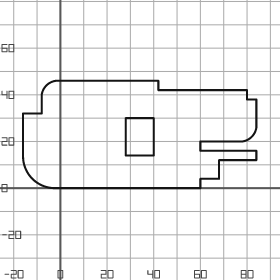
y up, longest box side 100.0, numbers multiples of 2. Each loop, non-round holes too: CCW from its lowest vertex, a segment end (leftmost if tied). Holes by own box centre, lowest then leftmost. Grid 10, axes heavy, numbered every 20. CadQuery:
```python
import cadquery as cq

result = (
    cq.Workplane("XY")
    .moveTo(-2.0, 0.0)
    .lineTo(60.0, 0.0)
    .lineTo(60.0, 4.0)
    .lineTo(68.0, 4.0)
    .lineTo(68.0, 12.0)
    .lineTo(84.0, 12.0)
    .lineTo(84.0, 16.0)
    .lineTo(60.0, 16.0)
    .lineTo(60.0, 20.0)
    .lineTo(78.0, 20.0)
    .threePointArc((82.0, 22.0), (84.0, 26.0))
    .lineTo(84.0, 38.0)
    .lineTo(80.0, 38.0)
    .lineTo(80.0, 42.0)
    .lineTo(42.0, 42.0)
    .lineTo(42.0, 46.0)
    .lineTo(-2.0, 46.0)
    .threePointArc((-6.0, 44.0), (-8.0, 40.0))
    .lineTo(-8.0, 32.0)
    .lineTo(-16.0, 32.0)
    .lineTo(-16.0, 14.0)
    .threePointArc((-12.0, 4.0), (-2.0, 0.0))
    .close()
    .moveTo(28.0, 14.0)
    .lineTo(40.0, 14.0)
    .lineTo(40.0, 30.0)
    .lineTo(28.0, 30.0)
    .close()
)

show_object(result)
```